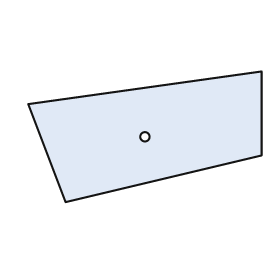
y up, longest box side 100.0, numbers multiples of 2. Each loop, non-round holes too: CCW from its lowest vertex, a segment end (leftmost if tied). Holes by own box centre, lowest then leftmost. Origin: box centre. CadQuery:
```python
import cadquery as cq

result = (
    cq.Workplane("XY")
    .moveTo(-34.0, -28.0)
    .lineTo(50.0, -8.0)
    .lineTo(50.0, 28.0)
    .lineTo(-50.0, 14.0)
    .close()
    .moveTo(0.0, 0.0)
    .circle(2.0)
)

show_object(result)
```